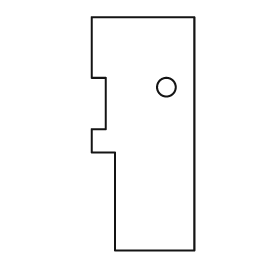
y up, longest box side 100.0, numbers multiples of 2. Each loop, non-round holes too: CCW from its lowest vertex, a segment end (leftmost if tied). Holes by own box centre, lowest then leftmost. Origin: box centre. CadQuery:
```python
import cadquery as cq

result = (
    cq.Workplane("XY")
    .moveTo(-12.0, -50.0)
    .lineTo(22.0, -50.0)
    .lineTo(22.0, 50.0)
    .lineTo(-22.0, 50.0)
    .lineTo(-22.0, 24.0)
    .lineTo(-16.0, 24.0)
    .lineTo(-16.0, 2.0)
    .lineTo(-22.0, 2.0)
    .lineTo(-22.0, -8.0)
    .lineTo(-12.0, -8.0)
    .close()
    .moveTo(10.0, 20.0)
    .circle(4.0)
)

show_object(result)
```